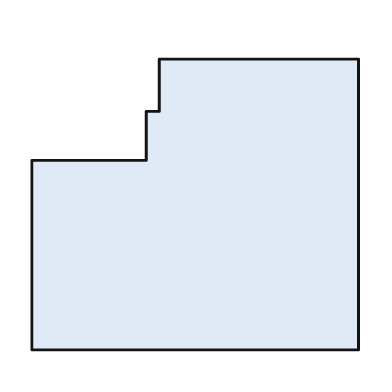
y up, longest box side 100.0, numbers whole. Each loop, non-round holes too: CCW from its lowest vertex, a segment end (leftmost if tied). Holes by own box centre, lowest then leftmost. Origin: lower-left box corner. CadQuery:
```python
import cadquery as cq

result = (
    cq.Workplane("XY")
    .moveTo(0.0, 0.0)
    .lineTo(100.0, 0.0)
    .lineTo(100.0, 89.0)
    .lineTo(39.0, 89.0)
    .lineTo(39.0, 73.0)
    .lineTo(35.0, 73.0)
    .lineTo(35.0, 58.0)
    .lineTo(0.0, 58.0)
    .close()
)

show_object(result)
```